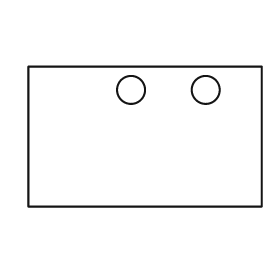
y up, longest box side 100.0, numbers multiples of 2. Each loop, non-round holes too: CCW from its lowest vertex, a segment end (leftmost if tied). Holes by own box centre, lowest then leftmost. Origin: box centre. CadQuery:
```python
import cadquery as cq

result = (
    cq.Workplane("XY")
    .moveTo(-50.0, -30.0)
    .lineTo(50.0, -30.0)
    .lineTo(50.0, 30.0)
    .lineTo(-50.0, 30.0)
    .close()
    .moveTo(-6.0, 20.0)
    .circle(6.0)
    .moveTo(26.0, 20.0)
    .circle(6.0)
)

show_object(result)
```